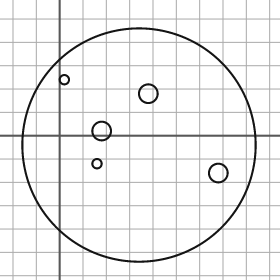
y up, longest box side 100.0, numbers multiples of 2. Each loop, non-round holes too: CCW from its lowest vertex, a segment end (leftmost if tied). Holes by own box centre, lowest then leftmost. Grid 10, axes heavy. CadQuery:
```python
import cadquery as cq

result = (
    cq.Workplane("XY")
    .moveTo(34.0, -4.0)
    .circle(50.0)
    .moveTo(68.0, -16.0)
    .circle(4.0)
    .moveTo(16.0, -12.0)
    .circle(2.0)
    .moveTo(18.0, 2.0)
    .circle(4.0)
    .moveTo(38.0, 18.0)
    .circle(4.0)
    .moveTo(2.0, 24.0)
    .circle(2.0)
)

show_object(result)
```